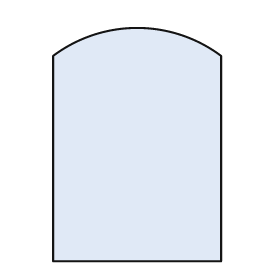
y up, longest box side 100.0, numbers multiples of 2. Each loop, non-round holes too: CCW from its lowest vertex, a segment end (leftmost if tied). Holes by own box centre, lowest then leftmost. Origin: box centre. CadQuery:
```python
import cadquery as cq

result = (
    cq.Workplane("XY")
    .moveTo(-36.0, -50.0)
    .lineTo(36.0, -50.0)
    .lineTo(36.0, 38.0)
    .threePointArc((0.0, 50.0), (-36.0, 38.0))
    .close()
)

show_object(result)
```